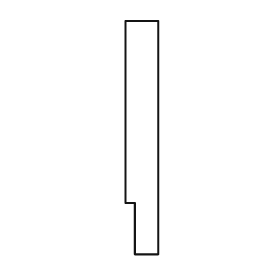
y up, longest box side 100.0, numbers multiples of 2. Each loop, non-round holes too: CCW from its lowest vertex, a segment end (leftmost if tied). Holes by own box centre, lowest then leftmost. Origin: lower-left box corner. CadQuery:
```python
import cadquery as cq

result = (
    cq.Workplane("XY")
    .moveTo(4.0, 0.0)
    .lineTo(14.0, 0.0)
    .lineTo(14.0, 100.0)
    .lineTo(0.0, 100.0)
    .lineTo(0.0, 22.0)
    .lineTo(4.0, 22.0)
    .close()
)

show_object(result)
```